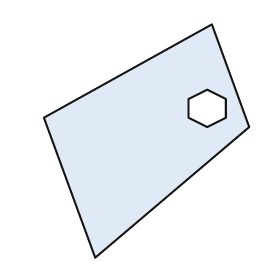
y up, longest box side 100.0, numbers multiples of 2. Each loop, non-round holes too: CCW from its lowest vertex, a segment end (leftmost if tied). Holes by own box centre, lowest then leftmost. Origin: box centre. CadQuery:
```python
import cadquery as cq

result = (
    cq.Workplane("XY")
    .moveTo(-22.0, -50.0)
    .lineTo(44.0, 6.0)
    .lineTo(28.0, 50.0)
    .lineTo(-44.0, 10.0)
    .close()
    .moveTo(26.0, 6.0)
    .lineTo(34.0, 10.0)
    .lineTo(34.0, 18.0)
    .lineTo(26.0, 22.0)
    .lineTo(18.0, 18.0)
    .lineTo(18.0, 10.0)
    .close()
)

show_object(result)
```